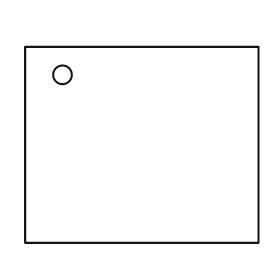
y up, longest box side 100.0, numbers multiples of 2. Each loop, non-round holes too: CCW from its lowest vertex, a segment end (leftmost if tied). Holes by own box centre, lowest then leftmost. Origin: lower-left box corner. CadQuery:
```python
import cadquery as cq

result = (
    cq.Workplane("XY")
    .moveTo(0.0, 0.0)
    .lineTo(100.0, 0.0)
    .lineTo(100.0, 84.0)
    .lineTo(0.0, 84.0)
    .close()
    .moveTo(16.0, 72.0)
    .circle(4.0)
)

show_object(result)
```